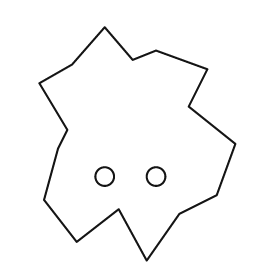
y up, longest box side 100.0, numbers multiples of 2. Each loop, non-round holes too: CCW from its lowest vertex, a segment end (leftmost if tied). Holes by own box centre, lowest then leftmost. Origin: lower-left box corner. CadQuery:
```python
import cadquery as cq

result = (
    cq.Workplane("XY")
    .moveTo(46.0, 0.0)
    .lineTo(60.0, 20.0)
    .lineTo(76.0, 28.0)
    .lineTo(84.0, 50.0)
    .lineTo(64.0, 66.0)
    .lineTo(72.0, 82.0)
    .lineTo(50.0, 90.0)
    .lineTo(40.0, 86.0)
    .lineTo(28.0, 100.0)
    .lineTo(14.0, 84.0)
    .lineTo(0.0, 76.0)
    .lineTo(12.0, 56.0)
    .lineTo(8.0, 48.0)
    .lineTo(2.0, 26.0)
    .lineTo(16.0, 8.0)
    .lineTo(34.0, 22.0)
    .close()
    .moveTo(28.0, 36.0)
    .circle(4.0)
    .moveTo(50.0, 36.0)
    .circle(4.0)
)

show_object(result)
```